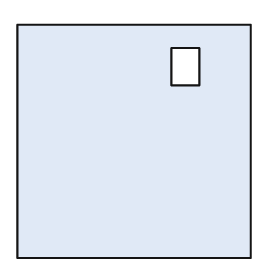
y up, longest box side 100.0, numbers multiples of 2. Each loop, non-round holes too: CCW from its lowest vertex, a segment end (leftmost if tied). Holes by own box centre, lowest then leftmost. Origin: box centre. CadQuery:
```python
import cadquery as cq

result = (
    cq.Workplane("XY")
    .moveTo(-50.0, -50.0)
    .lineTo(50.0, -50.0)
    .lineTo(50.0, 50.0)
    .lineTo(-50.0, 50.0)
    .close()
    .moveTo(16.0, 24.0)
    .lineTo(28.0, 24.0)
    .lineTo(28.0, 40.0)
    .lineTo(16.0, 40.0)
    .close()
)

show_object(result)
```